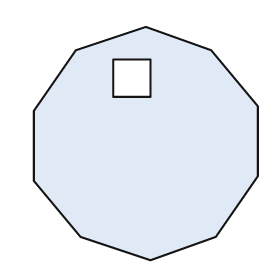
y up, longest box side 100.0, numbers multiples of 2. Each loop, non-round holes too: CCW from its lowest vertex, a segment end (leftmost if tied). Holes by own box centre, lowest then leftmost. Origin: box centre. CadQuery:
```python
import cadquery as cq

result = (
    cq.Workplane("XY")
    .moveTo(2.0, -50.0)
    .lineTo(30.0, -40.0)
    .lineTo(48.0, -14.0)
    .lineTo(48.0, 16.0)
    .lineTo(28.0, 40.0)
    .lineTo(0.0, 50.0)
    .lineTo(-30.0, 40.0)
    .lineTo(-48.0, 14.0)
    .lineTo(-48.0, -16.0)
    .lineTo(-28.0, -40.0)
    .close()
    .moveTo(-14.0, 20.0)
    .lineTo(2.0, 20.0)
    .lineTo(2.0, 36.0)
    .lineTo(-14.0, 36.0)
    .close()
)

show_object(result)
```